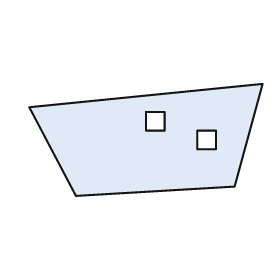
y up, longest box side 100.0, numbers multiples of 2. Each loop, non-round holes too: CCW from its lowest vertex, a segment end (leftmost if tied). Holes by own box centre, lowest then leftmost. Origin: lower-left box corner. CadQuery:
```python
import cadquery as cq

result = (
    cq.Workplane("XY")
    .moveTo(20.0, 0.0)
    .lineTo(88.0, 4.0)
    .lineTo(100.0, 48.0)
    .lineTo(0.0, 38.0)
    .close()
    .moveTo(72.0, 20.0)
    .lineTo(80.0, 20.0)
    .lineTo(80.0, 28.0)
    .lineTo(72.0, 28.0)
    .close()
    .moveTo(50.0, 28.0)
    .lineTo(58.0, 28.0)
    .lineTo(58.0, 36.0)
    .lineTo(50.0, 36.0)
    .close()
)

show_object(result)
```